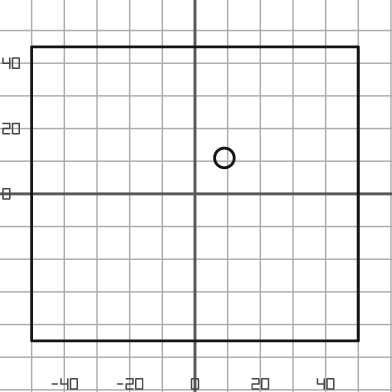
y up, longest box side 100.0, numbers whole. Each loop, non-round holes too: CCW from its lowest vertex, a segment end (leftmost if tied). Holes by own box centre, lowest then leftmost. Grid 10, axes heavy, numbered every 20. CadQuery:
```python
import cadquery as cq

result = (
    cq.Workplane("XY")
    .moveTo(-50.0, -45.0)
    .lineTo(50.0, -45.0)
    .lineTo(50.0, 45.0)
    .lineTo(-50.0, 45.0)
    .close()
    .moveTo(9.0, 11.0)
    .circle(3.0)
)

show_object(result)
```